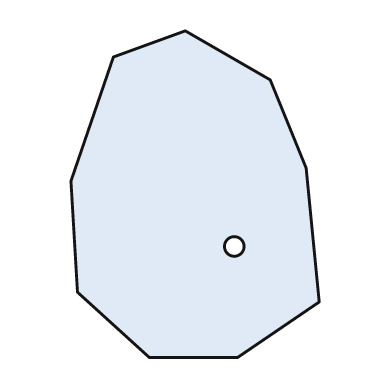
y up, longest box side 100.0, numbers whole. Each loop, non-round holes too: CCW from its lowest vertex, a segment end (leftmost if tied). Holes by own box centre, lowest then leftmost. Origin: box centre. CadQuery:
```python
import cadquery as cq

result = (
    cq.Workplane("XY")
    .moveTo(-14.0, -50.0)
    .lineTo(13.0, -50.0)
    .lineTo(38.0, -33.0)
    .lineTo(34.0, 8.0)
    .lineTo(23.0, 35.0)
    .lineTo(-3.0, 50.0)
    .lineTo(-25.0, 42.0)
    .lineTo(-38.0, 4.0)
    .lineTo(-36.0, -30.0)
    .close()
    .moveTo(12.0, -16.0)
    .circle(3.0)
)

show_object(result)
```